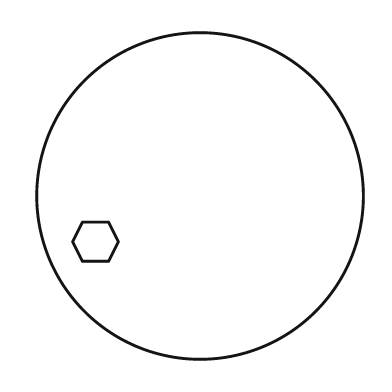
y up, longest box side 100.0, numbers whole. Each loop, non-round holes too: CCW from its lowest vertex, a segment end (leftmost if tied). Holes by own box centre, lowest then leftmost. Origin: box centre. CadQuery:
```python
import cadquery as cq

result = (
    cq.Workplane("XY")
    .moveTo(0.0, 0.0)
    .circle(50.0)
    .moveTo(-36.0, -20.0)
    .lineTo(-28.0, -20.0)
    .lineTo(-25.0, -14.0)
    .lineTo(-28.0, -8.0)
    .lineTo(-36.0, -8.0)
    .lineTo(-39.0, -14.0)
    .close()
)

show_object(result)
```